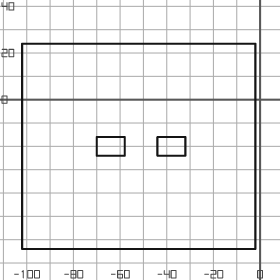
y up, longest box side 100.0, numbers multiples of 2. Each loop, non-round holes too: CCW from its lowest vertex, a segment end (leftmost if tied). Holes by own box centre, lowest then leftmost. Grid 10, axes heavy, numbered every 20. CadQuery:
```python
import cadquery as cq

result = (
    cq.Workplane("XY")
    .moveTo(-102.0, -64.0)
    .lineTo(-2.0, -64.0)
    .lineTo(-2.0, 24.0)
    .lineTo(-102.0, 24.0)
    .close()
    .moveTo(-70.0, -24.0)
    .lineTo(-58.0, -24.0)
    .lineTo(-58.0, -16.0)
    .lineTo(-70.0, -16.0)
    .close()
    .moveTo(-44.0, -24.0)
    .lineTo(-32.0, -24.0)
    .lineTo(-32.0, -16.0)
    .lineTo(-44.0, -16.0)
    .close()
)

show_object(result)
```